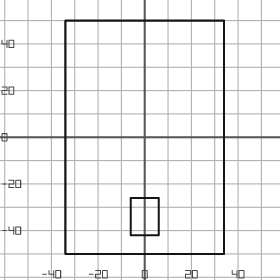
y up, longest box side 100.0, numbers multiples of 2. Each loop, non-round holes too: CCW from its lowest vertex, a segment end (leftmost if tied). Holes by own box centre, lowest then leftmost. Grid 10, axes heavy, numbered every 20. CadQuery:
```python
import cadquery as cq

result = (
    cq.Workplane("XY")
    .moveTo(-34.0, -50.0)
    .lineTo(34.0, -50.0)
    .lineTo(34.0, 50.0)
    .lineTo(-34.0, 50.0)
    .close()
    .moveTo(-6.0, -42.0)
    .lineTo(6.0, -42.0)
    .lineTo(6.0, -26.0)
    .lineTo(-6.0, -26.0)
    .close()
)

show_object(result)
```